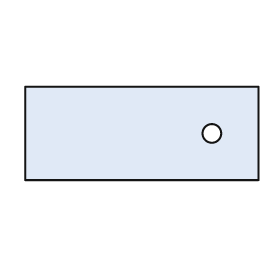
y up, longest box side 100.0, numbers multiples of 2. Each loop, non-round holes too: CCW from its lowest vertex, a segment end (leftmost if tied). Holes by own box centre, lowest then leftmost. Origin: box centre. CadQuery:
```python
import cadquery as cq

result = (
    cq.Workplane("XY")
    .moveTo(-50.0, -20.0)
    .lineTo(50.0, -20.0)
    .lineTo(50.0, 20.0)
    .lineTo(-50.0, 20.0)
    .close()
    .moveTo(30.0, 0.0)
    .circle(4.0)
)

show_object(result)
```